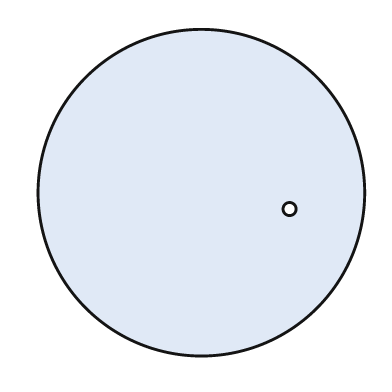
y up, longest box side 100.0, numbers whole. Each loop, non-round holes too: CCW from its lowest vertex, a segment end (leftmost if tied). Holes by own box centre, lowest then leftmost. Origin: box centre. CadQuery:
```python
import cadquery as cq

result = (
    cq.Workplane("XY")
    .moveTo(0.0, 0.0)
    .circle(50.0)
    .moveTo(27.0, -5.0)
    .circle(2.0)
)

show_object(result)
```